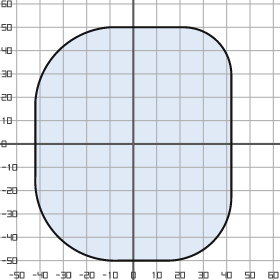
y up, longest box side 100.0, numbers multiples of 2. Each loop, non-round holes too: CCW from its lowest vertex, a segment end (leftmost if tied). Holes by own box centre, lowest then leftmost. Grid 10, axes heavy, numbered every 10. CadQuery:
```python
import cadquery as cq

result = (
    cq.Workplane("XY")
    .moveTo(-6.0, -50.0)
    .lineTo(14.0, -50.0)
    .threePointArc((34.0, -42.0), (42.0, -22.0))
    .lineTo(42.0, 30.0)
    .threePointArc((36.0, 44.0), (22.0, 50.0))
    .lineTo(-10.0, 50.0)
    .threePointArc((-32.0, 40.0), (-42.0, 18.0))
    .lineTo(-42.0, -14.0)
    .threePointArc((-32.0, -40.0), (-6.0, -50.0))
    .close()
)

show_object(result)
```